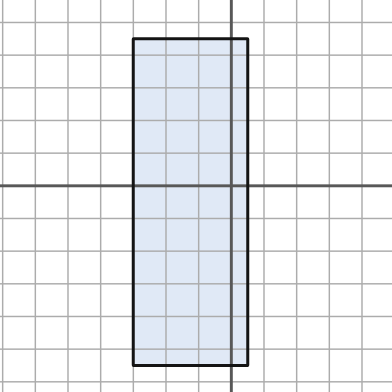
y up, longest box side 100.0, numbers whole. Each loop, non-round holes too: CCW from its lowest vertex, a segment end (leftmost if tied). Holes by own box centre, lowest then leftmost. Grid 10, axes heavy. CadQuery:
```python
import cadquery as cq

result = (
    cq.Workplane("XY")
    .moveTo(-30.0, -55.0)
    .lineTo(5.0, -55.0)
    .lineTo(5.0, 45.0)
    .lineTo(-30.0, 45.0)
    .close()
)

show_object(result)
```